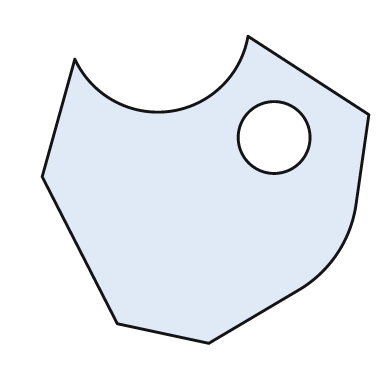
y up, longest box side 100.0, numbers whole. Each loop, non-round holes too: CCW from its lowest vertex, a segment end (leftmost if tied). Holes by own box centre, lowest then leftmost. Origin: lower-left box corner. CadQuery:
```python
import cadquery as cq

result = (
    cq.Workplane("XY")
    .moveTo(51.0, 0.0)
    .lineTo(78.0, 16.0)
    .threePointArc((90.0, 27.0), (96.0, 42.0))
    .lineTo(100.0, 70.0)
    .lineTo(63.0, 94.0)
    .threePointArc((39.0, 71.0), (10.0, 87.0))
    .lineTo(0.0, 51.0)
    .lineTo(23.0, 6.0)
    .close()
    .moveTo(71.0, 63.0)
    .circle(11.0)
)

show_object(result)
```